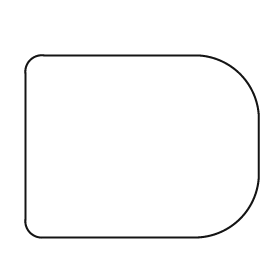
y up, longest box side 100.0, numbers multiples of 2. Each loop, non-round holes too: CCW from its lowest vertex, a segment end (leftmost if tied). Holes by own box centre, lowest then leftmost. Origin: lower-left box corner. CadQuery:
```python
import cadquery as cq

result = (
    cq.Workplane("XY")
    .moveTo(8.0, 0.0)
    .lineTo(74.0, 0.0)
    .threePointArc((92.0, 8.0), (100.0, 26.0))
    .lineTo(100.0, 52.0)
    .threePointArc((92.0, 70.0), (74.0, 78.0))
    .lineTo(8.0, 78.0)
    .threePointArc((2.0, 76.0), (0.0, 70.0))
    .lineTo(0.0, 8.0)
    .threePointArc((2.0, 2.0), (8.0, 0.0))
    .close()
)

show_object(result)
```